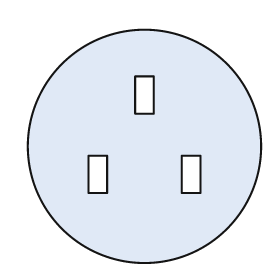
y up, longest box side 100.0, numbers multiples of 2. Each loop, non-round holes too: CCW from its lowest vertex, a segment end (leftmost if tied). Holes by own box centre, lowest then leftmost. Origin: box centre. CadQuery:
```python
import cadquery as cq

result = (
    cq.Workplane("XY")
    .moveTo(0.0, 0.0)
    .circle(50.0)
    .moveTo(-24.0, -20.0)
    .lineTo(-16.0, -20.0)
    .lineTo(-16.0, -4.0)
    .lineTo(-24.0, -4.0)
    .close()
    .moveTo(16.0, -20.0)
    .lineTo(24.0, -20.0)
    .lineTo(24.0, -4.0)
    .lineTo(16.0, -4.0)
    .close()
    .moveTo(-4.0, 14.0)
    .lineTo(4.0, 14.0)
    .lineTo(4.0, 30.0)
    .lineTo(-4.0, 30.0)
    .close()
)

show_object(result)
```